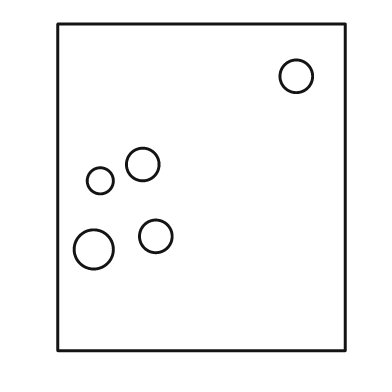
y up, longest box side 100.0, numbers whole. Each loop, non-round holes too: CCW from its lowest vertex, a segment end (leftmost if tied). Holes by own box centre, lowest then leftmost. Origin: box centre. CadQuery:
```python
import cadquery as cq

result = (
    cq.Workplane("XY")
    .moveTo(-44.0, -50.0)
    .lineTo(44.0, -50.0)
    .lineTo(44.0, 50.0)
    .lineTo(-44.0, 50.0)
    .close()
    .moveTo(-33.0, -19.0)
    .circle(6.0)
    .moveTo(-14.0, -15.0)
    .circle(5.0)
    .moveTo(-31.0, 2.0)
    .circle(4.0)
    .moveTo(-18.0, 7.0)
    .circle(5.0)
    .moveTo(29.0, 34.0)
    .circle(5.0)
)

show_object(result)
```